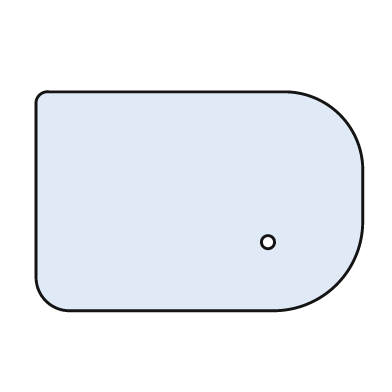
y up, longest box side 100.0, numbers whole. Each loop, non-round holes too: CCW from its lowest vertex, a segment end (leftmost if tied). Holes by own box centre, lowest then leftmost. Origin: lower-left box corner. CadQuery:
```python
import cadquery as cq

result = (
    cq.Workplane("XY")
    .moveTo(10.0, 0.0)
    .lineTo(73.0, 0.0)
    .threePointArc((92.0, 8.0), (100.0, 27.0))
    .lineTo(100.0, 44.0)
    .threePointArc((93.0, 60.0), (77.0, 67.0))
    .lineTo(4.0, 67.0)
    .threePointArc((1.0, 66.0), (0.0, 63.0))
    .lineTo(0.0, 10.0)
    .threePointArc((3.0, 3.0), (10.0, 0.0))
    .close()
    .moveTo(71.0, 21.0)
    .circle(2.0)
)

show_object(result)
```